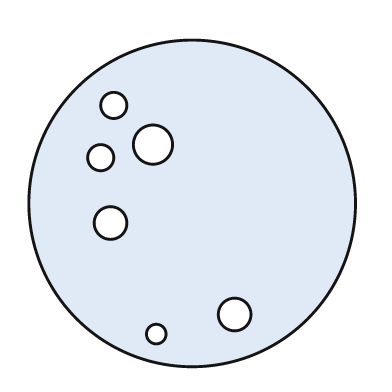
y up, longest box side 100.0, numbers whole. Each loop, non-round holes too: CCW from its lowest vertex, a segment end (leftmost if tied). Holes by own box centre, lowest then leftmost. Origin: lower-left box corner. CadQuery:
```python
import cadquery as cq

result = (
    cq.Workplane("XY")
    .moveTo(50.0, 50.0)
    .circle(50.0)
    .moveTo(39.0, 10.0)
    .circle(3.0)
    .moveTo(63.0, 16.0)
    .circle(5.0)
    .moveTo(25.0, 44.0)
    .circle(5.0)
    .moveTo(22.0, 64.0)
    .circle(4.0)
    .moveTo(38.0, 68.0)
    .circle(6.0)
    .moveTo(26.0, 80.0)
    .circle(4.0)
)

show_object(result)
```